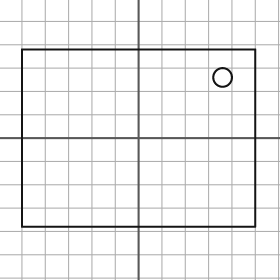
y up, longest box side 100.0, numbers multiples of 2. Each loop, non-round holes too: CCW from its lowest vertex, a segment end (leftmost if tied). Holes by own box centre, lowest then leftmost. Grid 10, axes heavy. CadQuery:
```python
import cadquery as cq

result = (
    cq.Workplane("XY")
    .moveTo(-50.0, -38.0)
    .lineTo(50.0, -38.0)
    .lineTo(50.0, 38.0)
    .lineTo(-50.0, 38.0)
    .close()
    .moveTo(36.0, 26.0)
    .circle(4.0)
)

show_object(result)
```